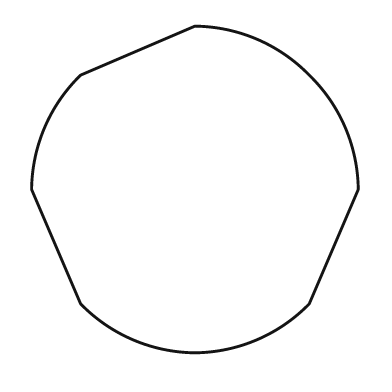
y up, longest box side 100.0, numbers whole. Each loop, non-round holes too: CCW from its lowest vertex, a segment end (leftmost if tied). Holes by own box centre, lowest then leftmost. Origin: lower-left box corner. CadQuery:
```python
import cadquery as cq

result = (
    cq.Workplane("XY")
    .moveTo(50.0, 0.0)
    .threePointArc((69.0, 4.0), (85.0, 15.0))
    .lineTo(100.0, 50.0)
    .threePointArc((96.0, 69.0), (85.0, 85.0))
    .threePointArc((69.0, 96.0), (50.0, 100.0))
    .lineTo(15.0, 85.0)
    .threePointArc((4.0, 69.0), (0.0, 50.0))
    .lineTo(15.0, 15.0)
    .threePointArc((31.0, 4.0), (50.0, 0.0))
    .close()
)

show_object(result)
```